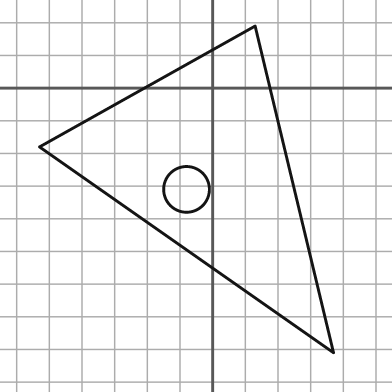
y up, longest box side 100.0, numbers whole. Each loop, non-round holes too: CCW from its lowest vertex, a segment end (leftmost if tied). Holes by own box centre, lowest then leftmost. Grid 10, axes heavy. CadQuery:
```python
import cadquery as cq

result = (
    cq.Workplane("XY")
    .moveTo(37.0, -81.0)
    .lineTo(13.0, 19.0)
    .lineTo(-53.0, -18.0)
    .close()
    .moveTo(-8.0, -31.0)
    .circle(7.0)
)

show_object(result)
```